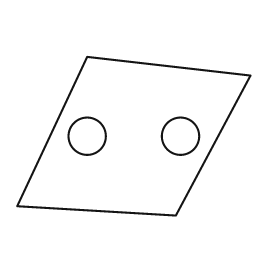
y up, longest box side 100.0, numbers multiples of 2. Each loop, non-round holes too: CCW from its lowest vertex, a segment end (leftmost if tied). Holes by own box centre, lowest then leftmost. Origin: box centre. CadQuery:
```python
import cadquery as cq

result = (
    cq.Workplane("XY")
    .moveTo(18.0, -34.0)
    .lineTo(50.0, 26.0)
    .lineTo(-20.0, 34.0)
    .lineTo(-50.0, -30.0)
    .close()
    .moveTo(-20.0, 0.0)
    .circle(8.0)
    .moveTo(20.0, 0.0)
    .circle(8.0)
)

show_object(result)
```